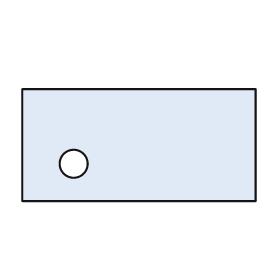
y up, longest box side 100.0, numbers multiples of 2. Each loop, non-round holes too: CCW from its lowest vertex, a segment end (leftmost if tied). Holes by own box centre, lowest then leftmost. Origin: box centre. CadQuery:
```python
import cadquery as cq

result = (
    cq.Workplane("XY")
    .moveTo(-50.0, -24.0)
    .lineTo(50.0, -24.0)
    .lineTo(50.0, 24.0)
    .lineTo(-50.0, 24.0)
    .close()
    .moveTo(-28.0, -8.0)
    .circle(6.0)
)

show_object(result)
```